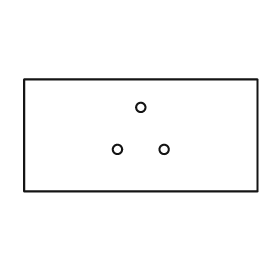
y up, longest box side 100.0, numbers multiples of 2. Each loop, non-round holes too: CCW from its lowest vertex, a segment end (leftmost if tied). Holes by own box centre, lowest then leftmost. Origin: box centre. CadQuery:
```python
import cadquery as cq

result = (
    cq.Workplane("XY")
    .moveTo(-50.0, -24.0)
    .lineTo(50.0, -24.0)
    .lineTo(50.0, 24.0)
    .lineTo(-50.0, 24.0)
    .close()
    .moveTo(-10.0, -6.0)
    .circle(2.0)
    .moveTo(10.0, -6.0)
    .circle(2.0)
    .moveTo(0.0, 12.0)
    .circle(2.0)
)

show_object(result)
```